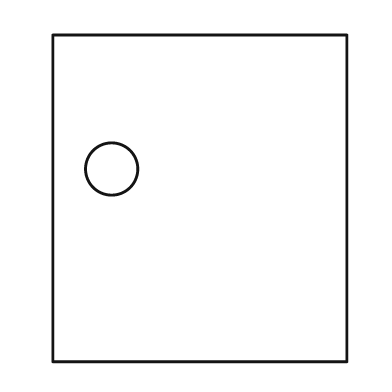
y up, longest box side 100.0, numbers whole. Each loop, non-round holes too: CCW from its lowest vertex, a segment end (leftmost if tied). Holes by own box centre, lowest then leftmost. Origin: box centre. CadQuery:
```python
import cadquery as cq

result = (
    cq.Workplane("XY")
    .moveTo(-45.0, -50.0)
    .lineTo(45.0, -50.0)
    .lineTo(45.0, 50.0)
    .lineTo(-45.0, 50.0)
    .close()
    .moveTo(-27.0, 9.0)
    .circle(8.0)
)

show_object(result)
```